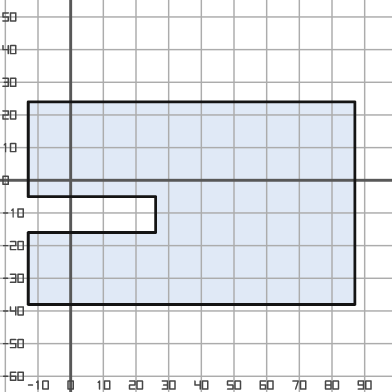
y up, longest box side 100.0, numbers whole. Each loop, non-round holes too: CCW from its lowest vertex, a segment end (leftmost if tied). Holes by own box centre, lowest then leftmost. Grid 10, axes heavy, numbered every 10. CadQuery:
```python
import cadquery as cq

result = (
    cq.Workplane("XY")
    .moveTo(-13.0, -38.0)
    .lineTo(87.0, -38.0)
    .lineTo(87.0, 24.0)
    .lineTo(-13.0, 24.0)
    .lineTo(-13.0, -5.0)
    .lineTo(26.0, -5.0)
    .lineTo(26.0, -16.0)
    .lineTo(-13.0, -16.0)
    .close()
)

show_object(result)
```